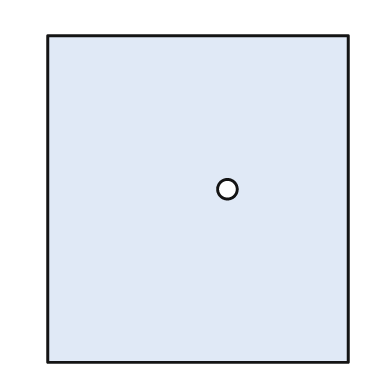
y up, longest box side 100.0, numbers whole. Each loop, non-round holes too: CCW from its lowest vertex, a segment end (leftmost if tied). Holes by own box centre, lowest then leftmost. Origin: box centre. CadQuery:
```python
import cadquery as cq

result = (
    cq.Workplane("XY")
    .moveTo(-46.0, -50.0)
    .lineTo(46.0, -50.0)
    .lineTo(46.0, 50.0)
    .lineTo(-46.0, 50.0)
    .close()
    .moveTo(9.0, 3.0)
    .circle(3.0)
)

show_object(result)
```